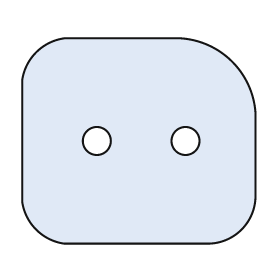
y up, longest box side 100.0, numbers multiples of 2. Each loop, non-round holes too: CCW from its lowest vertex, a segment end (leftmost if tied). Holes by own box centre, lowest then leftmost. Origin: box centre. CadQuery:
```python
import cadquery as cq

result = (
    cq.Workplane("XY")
    .moveTo(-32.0, -44.0)
    .lineTo(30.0, -44.0)
    .threePointArc((44.0, -38.0), (50.0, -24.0))
    .lineTo(50.0, 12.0)
    .threePointArc((40.0, 34.0), (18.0, 44.0))
    .lineTo(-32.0, 44.0)
    .threePointArc((-44.0, 38.0), (-50.0, 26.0))
    .lineTo(-50.0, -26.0)
    .threePointArc((-44.0, -38.0), (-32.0, -44.0))
    .close()
    .moveTo(-18.0, 0.0)
    .circle(6.0)
    .moveTo(20.0, 0.0)
    .circle(6.0)
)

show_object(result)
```